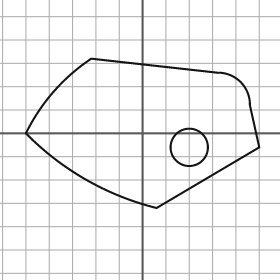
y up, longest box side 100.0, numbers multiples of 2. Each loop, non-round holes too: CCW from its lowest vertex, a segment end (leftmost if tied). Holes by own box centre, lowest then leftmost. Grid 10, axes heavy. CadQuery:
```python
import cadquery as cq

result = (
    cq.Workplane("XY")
    .moveTo(6.0, -32.0)
    .lineTo(50.0, -6.0)
    .lineTo(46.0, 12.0)
    .threePointArc((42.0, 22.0), (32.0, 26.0))
    .lineTo(-22.0, 32.0)
    .threePointArc((-38.0, 18.0), (-50.0, 0.0))
    .threePointArc((-24.0, -20.0), (6.0, -32.0))
    .close()
    .moveTo(20.0, -6.0)
    .circle(8.0)
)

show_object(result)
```